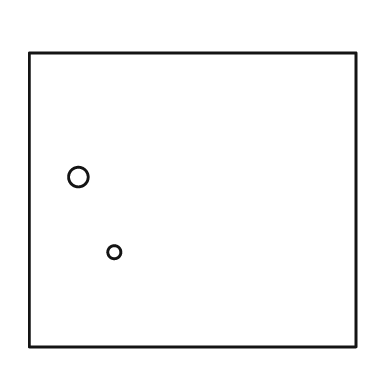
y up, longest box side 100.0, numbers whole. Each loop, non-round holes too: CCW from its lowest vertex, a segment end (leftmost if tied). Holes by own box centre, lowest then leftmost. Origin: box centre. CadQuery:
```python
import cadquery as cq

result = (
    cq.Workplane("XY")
    .moveTo(-50.0, -45.0)
    .lineTo(50.0, -45.0)
    .lineTo(50.0, 45.0)
    .lineTo(-50.0, 45.0)
    .close()
    .moveTo(-24.0, -16.0)
    .circle(2.0)
    .moveTo(-35.0, 7.0)
    .circle(3.0)
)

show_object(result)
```